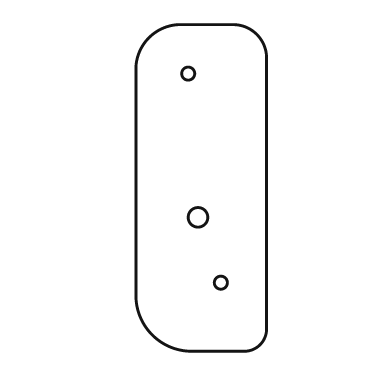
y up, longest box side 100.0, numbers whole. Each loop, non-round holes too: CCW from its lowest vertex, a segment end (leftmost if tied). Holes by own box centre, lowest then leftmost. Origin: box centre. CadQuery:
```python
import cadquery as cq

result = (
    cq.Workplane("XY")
    .moveTo(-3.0, -50.0)
    .lineTo(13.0, -50.0)
    .threePointArc((18.0, -48.0), (20.0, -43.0))
    .lineTo(20.0, 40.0)
    .threePointArc((17.0, 47.0), (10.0, 50.0))
    .lineTo(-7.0, 50.0)
    .threePointArc((-16.0, 46.0), (-20.0, 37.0))
    .lineTo(-20.0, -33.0)
    .threePointArc((-15.0, -45.0), (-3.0, -50.0))
    .close()
    .moveTo(6.0, -29.0)
    .circle(2.0)
    .moveTo(-1.0, -9.0)
    .circle(3.0)
    .moveTo(-4.0, 35.0)
    .circle(2.0)
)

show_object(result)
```